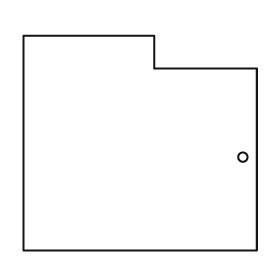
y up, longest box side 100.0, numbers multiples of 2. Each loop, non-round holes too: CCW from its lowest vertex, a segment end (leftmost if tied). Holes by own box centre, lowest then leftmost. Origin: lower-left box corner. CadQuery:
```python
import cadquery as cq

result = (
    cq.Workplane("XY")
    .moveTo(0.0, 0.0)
    .lineTo(100.0, 0.0)
    .lineTo(100.0, 78.0)
    .lineTo(56.0, 78.0)
    .lineTo(56.0, 92.0)
    .lineTo(0.0, 92.0)
    .close()
    .moveTo(94.0, 40.0)
    .circle(2.0)
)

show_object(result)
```